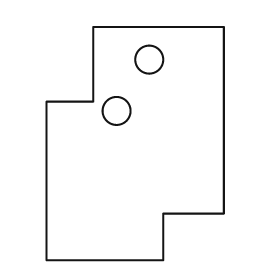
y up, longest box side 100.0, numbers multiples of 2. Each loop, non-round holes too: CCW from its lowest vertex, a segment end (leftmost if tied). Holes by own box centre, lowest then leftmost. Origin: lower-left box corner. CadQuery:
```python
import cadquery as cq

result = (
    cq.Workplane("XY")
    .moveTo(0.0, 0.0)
    .lineTo(50.0, 0.0)
    .lineTo(50.0, 20.0)
    .lineTo(76.0, 20.0)
    .lineTo(76.0, 100.0)
    .lineTo(20.0, 100.0)
    .lineTo(20.0, 68.0)
    .lineTo(0.0, 68.0)
    .close()
    .moveTo(30.0, 64.0)
    .circle(6.0)
    .moveTo(44.0, 86.0)
    .circle(6.0)
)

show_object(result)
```